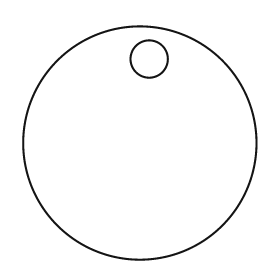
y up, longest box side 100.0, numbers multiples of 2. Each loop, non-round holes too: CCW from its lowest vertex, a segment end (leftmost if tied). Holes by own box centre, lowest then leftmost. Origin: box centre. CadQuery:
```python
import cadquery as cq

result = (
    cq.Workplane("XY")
    .moveTo(0.0, 0.0)
    .circle(50.0)
    .moveTo(4.0, 36.0)
    .circle(8.0)
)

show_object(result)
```